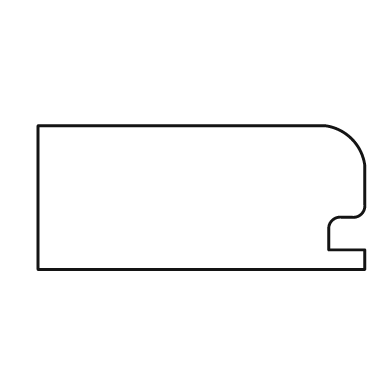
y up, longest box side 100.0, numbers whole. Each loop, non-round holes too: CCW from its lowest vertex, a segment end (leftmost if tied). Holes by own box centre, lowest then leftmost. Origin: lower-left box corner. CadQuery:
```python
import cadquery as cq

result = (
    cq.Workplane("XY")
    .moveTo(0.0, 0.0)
    .lineTo(100.0, 0.0)
    .lineTo(100.0, 6.0)
    .lineTo(89.0, 6.0)
    .lineTo(89.0, 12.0)
    .threePointArc((90.0, 15.0), (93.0, 16.0))
    .lineTo(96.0, 16.0)
    .threePointArc((99.0, 17.0), (100.0, 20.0))
    .lineTo(100.0, 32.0)
    .threePointArc((96.0, 40.0), (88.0, 44.0))
    .lineTo(0.0, 44.0)
    .close()
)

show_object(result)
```